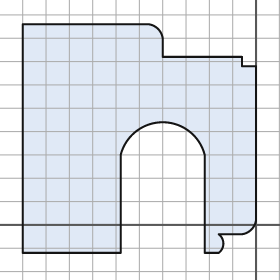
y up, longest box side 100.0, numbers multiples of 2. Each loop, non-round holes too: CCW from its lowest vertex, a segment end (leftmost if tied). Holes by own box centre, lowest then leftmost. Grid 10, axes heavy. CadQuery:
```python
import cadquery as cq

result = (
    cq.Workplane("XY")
    .moveTo(-100.0, -12.0)
    .lineTo(-58.0, -12.0)
    .lineTo(-58.0, 30.0)
    .threePointArc((-40.0, 44.0), (-22.0, 30.0))
    .lineTo(-22.0, -12.0)
    .lineTo(-16.0, -12.0)
    .threePointArc((-14.0, -8.0), (-16.0, -4.0))
    .lineTo(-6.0, -4.0)
    .threePointArc((-2.0, -2.0), (0.0, 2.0))
    .lineTo(0.0, 68.0)
    .lineTo(-6.0, 68.0)
    .lineTo(-6.0, 72.0)
    .lineTo(-40.0, 72.0)
    .lineTo(-40.0, 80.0)
    .threePointArc((-42.0, 84.0), (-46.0, 86.0))
    .lineTo(-100.0, 86.0)
    .close()
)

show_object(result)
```